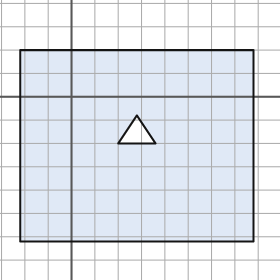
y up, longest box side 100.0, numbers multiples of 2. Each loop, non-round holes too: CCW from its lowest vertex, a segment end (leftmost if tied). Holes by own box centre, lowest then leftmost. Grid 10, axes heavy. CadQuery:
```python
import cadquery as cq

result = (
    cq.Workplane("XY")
    .moveTo(-22.0, -62.0)
    .lineTo(78.0, -62.0)
    .lineTo(78.0, 20.0)
    .lineTo(-22.0, 20.0)
    .close()
    .moveTo(20.0, -20.0)
    .lineTo(36.0, -20.0)
    .lineTo(28.0, -8.0)
    .close()
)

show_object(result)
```